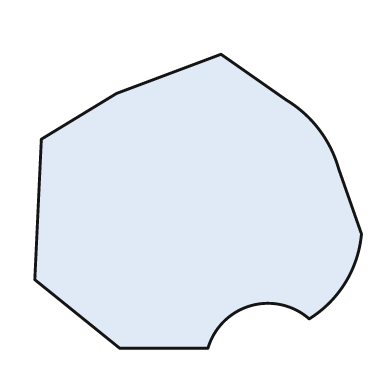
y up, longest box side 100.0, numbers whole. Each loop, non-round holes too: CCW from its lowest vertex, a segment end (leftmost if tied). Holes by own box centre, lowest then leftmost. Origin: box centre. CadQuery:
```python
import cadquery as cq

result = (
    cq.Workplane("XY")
    .moveTo(-24.0, -45.0)
    .lineTo(3.0, -45.0)
    .threePointArc((16.0, -32.0), (34.0, -36.0))
    .threePointArc((45.0, -25.0), (50.0, -10.0))
    .lineTo(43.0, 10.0)
    .threePointArc((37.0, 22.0), (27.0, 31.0))
    .lineTo(7.0, 45.0)
    .lineTo(-25.0, 33.0)
    .lineTo(-48.0, 19.0)
    .lineTo(-50.0, -24.0)
    .close()
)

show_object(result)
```